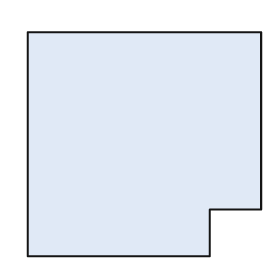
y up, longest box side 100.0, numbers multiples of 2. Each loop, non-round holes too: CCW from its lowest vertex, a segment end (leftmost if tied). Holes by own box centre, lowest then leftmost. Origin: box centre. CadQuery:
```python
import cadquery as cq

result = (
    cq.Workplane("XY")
    .moveTo(-50.0, -48.0)
    .lineTo(28.0, -48.0)
    .lineTo(28.0, -28.0)
    .lineTo(50.0, -28.0)
    .lineTo(50.0, 48.0)
    .lineTo(-50.0, 48.0)
    .close()
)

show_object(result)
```